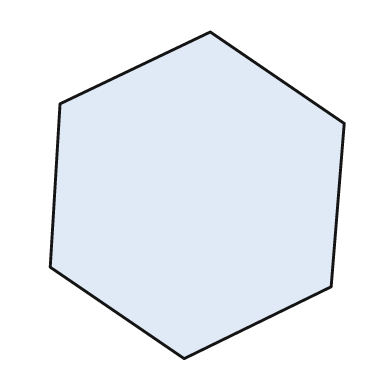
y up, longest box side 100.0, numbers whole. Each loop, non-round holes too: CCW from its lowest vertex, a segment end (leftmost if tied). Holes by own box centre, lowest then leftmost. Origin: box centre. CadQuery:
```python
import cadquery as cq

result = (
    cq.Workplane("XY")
    .moveTo(-4.0, -50.0)
    .lineTo(41.0, -28.0)
    .lineTo(45.0, 22.0)
    .lineTo(4.0, 50.0)
    .lineTo(-42.0, 28.0)
    .lineTo(-45.0, -22.0)
    .close()
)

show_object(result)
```